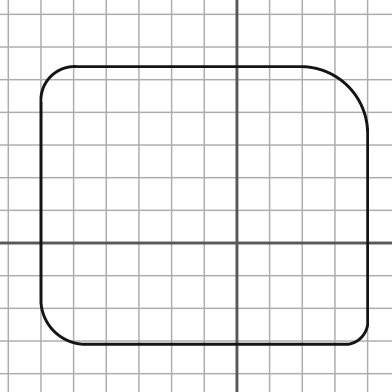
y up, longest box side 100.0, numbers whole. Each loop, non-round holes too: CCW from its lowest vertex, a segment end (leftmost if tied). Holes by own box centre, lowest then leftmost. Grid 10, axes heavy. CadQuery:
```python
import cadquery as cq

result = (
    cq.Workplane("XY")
    .moveTo(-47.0, -31.0)
    .lineTo(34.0, -31.0)
    .threePointArc((38.0, -29.0), (40.0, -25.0))
    .lineTo(40.0, 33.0)
    .threePointArc((34.0, 48.0), (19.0, 54.0))
    .lineTo(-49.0, 54.0)
    .threePointArc((-57.0, 51.0), (-60.0, 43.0))
    .lineTo(-60.0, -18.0)
    .threePointArc((-56.0, -27.0), (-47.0, -31.0))
    .close()
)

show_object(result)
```